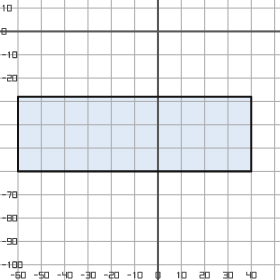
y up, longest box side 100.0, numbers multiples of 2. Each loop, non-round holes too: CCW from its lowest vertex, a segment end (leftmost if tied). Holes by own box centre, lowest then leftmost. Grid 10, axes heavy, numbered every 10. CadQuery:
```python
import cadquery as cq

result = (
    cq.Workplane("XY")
    .moveTo(-60.0, -60.0)
    .lineTo(40.0, -60.0)
    .lineTo(40.0, -28.0)
    .lineTo(-60.0, -28.0)
    .close()
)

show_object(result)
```